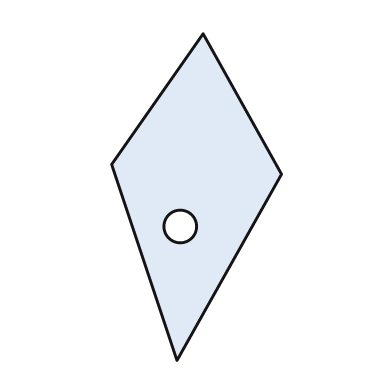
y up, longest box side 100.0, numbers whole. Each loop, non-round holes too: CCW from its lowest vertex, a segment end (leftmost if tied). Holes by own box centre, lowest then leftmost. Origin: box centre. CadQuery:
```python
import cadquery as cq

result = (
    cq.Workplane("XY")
    .moveTo(-6.0, -50.0)
    .lineTo(26.0, 7.0)
    .lineTo(2.0, 50.0)
    .lineTo(-26.0, 10.0)
    .close()
    .moveTo(-5.0, -9.0)
    .circle(5.0)
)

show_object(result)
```